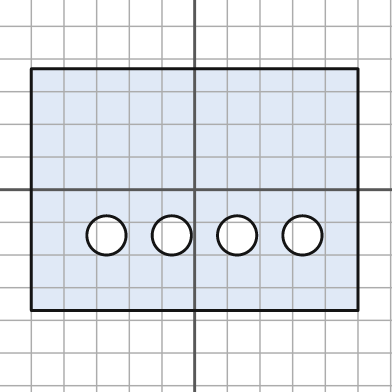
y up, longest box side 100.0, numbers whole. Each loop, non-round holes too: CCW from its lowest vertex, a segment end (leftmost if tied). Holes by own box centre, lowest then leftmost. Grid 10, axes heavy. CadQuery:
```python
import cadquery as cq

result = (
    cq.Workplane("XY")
    .moveTo(-50.0, -37.0)
    .lineTo(50.0, -37.0)
    .lineTo(50.0, 37.0)
    .lineTo(-50.0, 37.0)
    .close()
    .moveTo(-27.0, -14.0)
    .circle(6.0)
    .moveTo(-7.0, -14.0)
    .circle(6.0)
    .moveTo(13.0, -14.0)
    .circle(6.0)
    .moveTo(33.0, -14.0)
    .circle(6.0)
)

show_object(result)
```